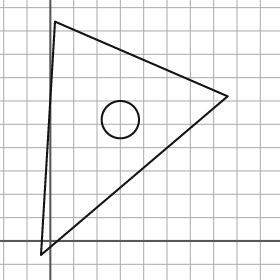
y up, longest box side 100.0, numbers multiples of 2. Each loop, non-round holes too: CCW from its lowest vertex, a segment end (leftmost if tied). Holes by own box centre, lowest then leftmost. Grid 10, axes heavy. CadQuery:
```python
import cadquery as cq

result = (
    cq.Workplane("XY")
    .moveTo(-4.0, -6.0)
    .lineTo(76.0, 62.0)
    .lineTo(2.0, 94.0)
    .close()
    .moveTo(30.0, 52.0)
    .circle(8.0)
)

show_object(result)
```